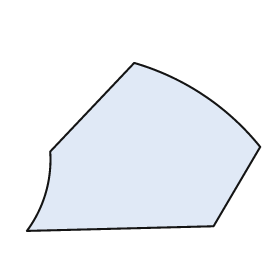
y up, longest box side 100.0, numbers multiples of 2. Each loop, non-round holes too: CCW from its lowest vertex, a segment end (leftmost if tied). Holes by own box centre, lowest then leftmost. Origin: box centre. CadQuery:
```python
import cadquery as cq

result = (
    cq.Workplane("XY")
    .moveTo(-50.0, -36.0)
    .lineTo(30.0, -34.0)
    .lineTo(50.0, 0.0)
    .threePointArc((26.0, 22.0), (-4.0, 36.0))
    .lineTo(-40.0, -2.0)
    .threePointArc((-42.0, -20.0), (-50.0, -36.0))
    .close()
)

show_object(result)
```